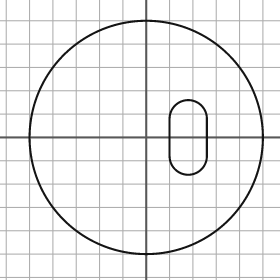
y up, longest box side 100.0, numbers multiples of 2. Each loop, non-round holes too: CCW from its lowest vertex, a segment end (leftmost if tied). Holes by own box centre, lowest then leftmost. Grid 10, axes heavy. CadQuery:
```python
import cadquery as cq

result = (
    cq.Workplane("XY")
    .moveTo(0.0, 0.0)
    .circle(50.0)
    .moveTo(10.0, -8.0)
    .threePointArc((18.0, -16.0), (26.0, -8.0))
    .lineTo(26.0, 8.0)
    .threePointArc((18.0, 16.0), (10.0, 8.0))
    .close()
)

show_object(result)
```